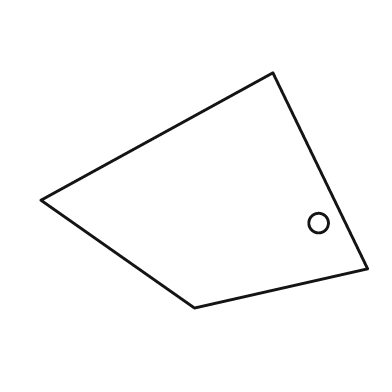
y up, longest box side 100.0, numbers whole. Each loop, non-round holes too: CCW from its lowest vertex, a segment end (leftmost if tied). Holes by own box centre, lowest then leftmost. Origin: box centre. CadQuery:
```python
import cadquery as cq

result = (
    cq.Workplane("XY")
    .moveTo(-3.0, -36.0)
    .lineTo(50.0, -24.0)
    .lineTo(21.0, 36.0)
    .lineTo(-50.0, -3.0)
    .close()
    .moveTo(35.0, -10.0)
    .circle(3.0)
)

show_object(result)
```